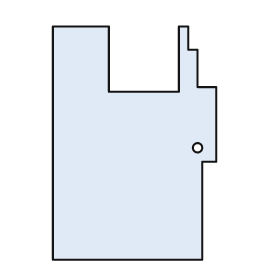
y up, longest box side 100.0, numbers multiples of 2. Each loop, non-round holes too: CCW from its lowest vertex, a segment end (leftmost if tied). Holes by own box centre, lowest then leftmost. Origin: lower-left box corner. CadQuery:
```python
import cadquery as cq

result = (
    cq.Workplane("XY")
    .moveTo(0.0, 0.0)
    .lineTo(64.0, 0.0)
    .lineTo(64.0, 42.0)
    .lineTo(70.0, 42.0)
    .lineTo(70.0, 74.0)
    .lineTo(62.0, 74.0)
    .lineTo(62.0, 90.0)
    .lineTo(58.0, 90.0)
    .lineTo(58.0, 100.0)
    .lineTo(54.0, 100.0)
    .lineTo(54.0, 72.0)
    .lineTo(24.0, 72.0)
    .lineTo(24.0, 100.0)
    .lineTo(0.0, 100.0)
    .close()
    .moveTo(62.0, 48.0)
    .circle(2.0)
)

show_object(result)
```